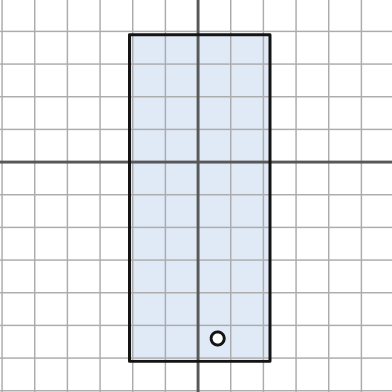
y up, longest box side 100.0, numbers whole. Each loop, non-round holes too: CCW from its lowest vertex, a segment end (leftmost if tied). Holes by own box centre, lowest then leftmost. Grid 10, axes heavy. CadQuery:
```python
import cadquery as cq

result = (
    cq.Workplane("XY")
    .moveTo(-21.0, -61.0)
    .lineTo(22.0, -61.0)
    .lineTo(22.0, 39.0)
    .lineTo(-21.0, 39.0)
    .close()
    .moveTo(6.0, -54.0)
    .circle(2.0)
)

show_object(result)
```